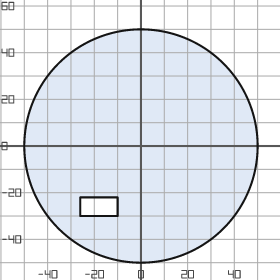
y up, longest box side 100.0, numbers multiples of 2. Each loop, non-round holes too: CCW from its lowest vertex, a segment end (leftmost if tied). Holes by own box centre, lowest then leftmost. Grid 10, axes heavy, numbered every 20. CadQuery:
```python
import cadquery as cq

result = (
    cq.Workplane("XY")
    .moveTo(0.0, 0.0)
    .circle(50.0)
    .moveTo(-26.0, -30.0)
    .lineTo(-10.0, -30.0)
    .lineTo(-10.0, -22.0)
    .lineTo(-26.0, -22.0)
    .close()
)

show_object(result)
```